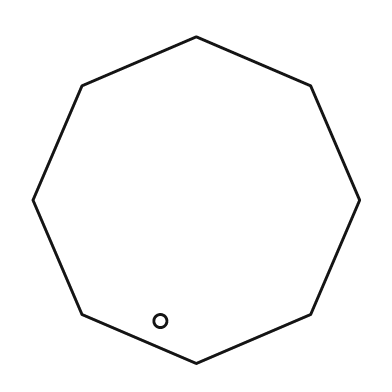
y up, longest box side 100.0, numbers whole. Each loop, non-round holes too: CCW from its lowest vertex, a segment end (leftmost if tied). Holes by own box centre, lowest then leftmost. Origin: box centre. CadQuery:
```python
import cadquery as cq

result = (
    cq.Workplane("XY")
    .moveTo(0.0, -50.0)
    .lineTo(35.0, -35.0)
    .lineTo(50.0, 0.0)
    .lineTo(35.0, 35.0)
    .lineTo(0.0, 50.0)
    .lineTo(-35.0, 35.0)
    .lineTo(-50.0, 0.0)
    .lineTo(-35.0, -35.0)
    .close()
    .moveTo(-11.0, -37.0)
    .circle(2.0)
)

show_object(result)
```